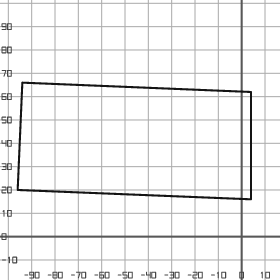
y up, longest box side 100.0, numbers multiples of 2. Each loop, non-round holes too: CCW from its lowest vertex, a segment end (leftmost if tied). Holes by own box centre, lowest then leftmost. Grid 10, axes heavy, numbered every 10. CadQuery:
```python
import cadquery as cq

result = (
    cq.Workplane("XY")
    .moveTo(4.0, 16.0)
    .lineTo(4.0, 62.0)
    .lineTo(-94.0, 66.0)
    .lineTo(-96.0, 20.0)
    .close()
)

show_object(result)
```